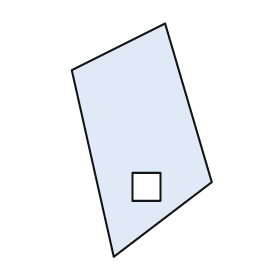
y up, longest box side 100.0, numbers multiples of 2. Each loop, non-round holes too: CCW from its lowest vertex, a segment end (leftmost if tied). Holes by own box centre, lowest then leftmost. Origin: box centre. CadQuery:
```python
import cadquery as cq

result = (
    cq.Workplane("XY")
    .moveTo(-12.0, -50.0)
    .lineTo(30.0, -18.0)
    .lineTo(10.0, 50.0)
    .lineTo(-30.0, 30.0)
    .close()
    .moveTo(-4.0, -26.0)
    .lineTo(8.0, -26.0)
    .lineTo(8.0, -14.0)
    .lineTo(-4.0, -14.0)
    .close()
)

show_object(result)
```